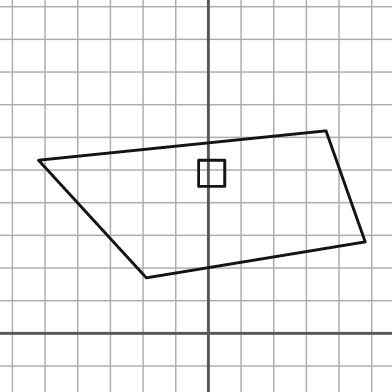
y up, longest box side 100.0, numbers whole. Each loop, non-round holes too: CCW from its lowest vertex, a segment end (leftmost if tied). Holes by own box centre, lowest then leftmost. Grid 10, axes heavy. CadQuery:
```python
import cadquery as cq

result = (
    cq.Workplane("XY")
    .moveTo(-19.0, 17.0)
    .lineTo(48.0, 28.0)
    .lineTo(36.0, 62.0)
    .lineTo(-52.0, 53.0)
    .close()
    .moveTo(-3.0, 45.0)
    .lineTo(5.0, 45.0)
    .lineTo(5.0, 53.0)
    .lineTo(-3.0, 53.0)
    .close()
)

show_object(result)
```